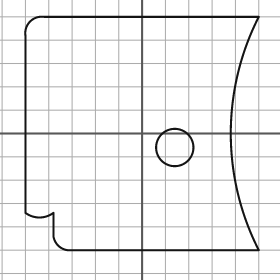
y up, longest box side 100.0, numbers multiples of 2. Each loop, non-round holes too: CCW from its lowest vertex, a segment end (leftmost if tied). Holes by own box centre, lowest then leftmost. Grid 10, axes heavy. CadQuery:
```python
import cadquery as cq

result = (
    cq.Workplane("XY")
    .moveTo(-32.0, -50.0)
    .lineTo(50.0, -50.0)
    .threePointArc((38.0, 0.0), (50.0, 50.0))
    .lineTo(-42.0, 50.0)
    .threePointArc((-48.0, 48.0), (-50.0, 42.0))
    .lineTo(-50.0, -34.0)
    .threePointArc((-44.0, -36.0), (-38.0, -34.0))
    .lineTo(-38.0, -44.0)
    .threePointArc((-36.0, -48.0), (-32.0, -50.0))
    .close()
    .moveTo(14.0, -6.0)
    .circle(8.0)
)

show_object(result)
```